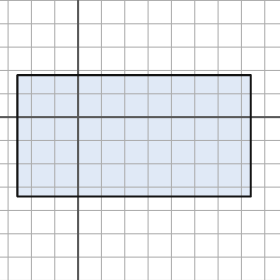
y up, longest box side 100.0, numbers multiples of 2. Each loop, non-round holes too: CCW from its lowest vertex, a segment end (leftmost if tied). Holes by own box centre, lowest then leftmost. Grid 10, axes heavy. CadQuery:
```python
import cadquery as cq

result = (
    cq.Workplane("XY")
    .moveTo(-26.0, -34.0)
    .lineTo(74.0, -34.0)
    .lineTo(74.0, 18.0)
    .lineTo(-26.0, 18.0)
    .close()
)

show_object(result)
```